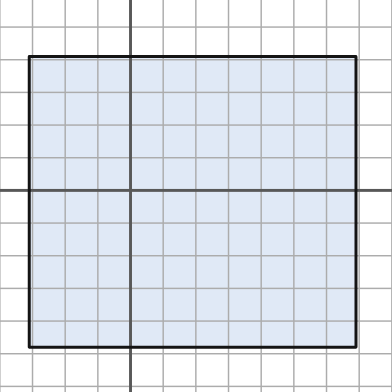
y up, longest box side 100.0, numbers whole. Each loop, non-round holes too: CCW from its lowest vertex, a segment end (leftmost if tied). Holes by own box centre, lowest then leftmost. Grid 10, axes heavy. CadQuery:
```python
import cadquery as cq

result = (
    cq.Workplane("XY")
    .moveTo(-31.0, -48.0)
    .lineTo(69.0, -48.0)
    .lineTo(69.0, 41.0)
    .lineTo(-31.0, 41.0)
    .close()
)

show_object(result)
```